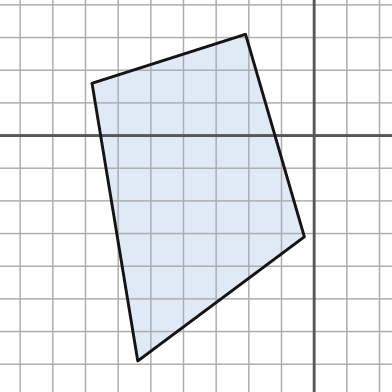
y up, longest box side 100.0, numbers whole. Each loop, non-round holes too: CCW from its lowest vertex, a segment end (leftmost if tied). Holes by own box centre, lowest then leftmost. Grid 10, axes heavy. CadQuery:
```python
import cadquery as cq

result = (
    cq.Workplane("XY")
    .moveTo(-54.0, -69.0)
    .lineTo(-3.0, -31.0)
    .lineTo(-21.0, 31.0)
    .lineTo(-68.0, 16.0)
    .close()
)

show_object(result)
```